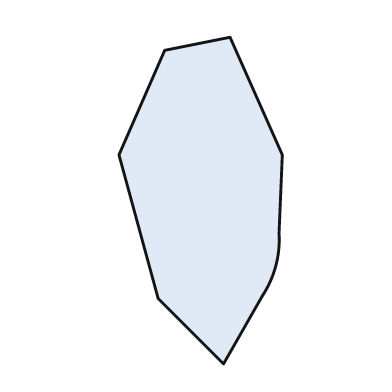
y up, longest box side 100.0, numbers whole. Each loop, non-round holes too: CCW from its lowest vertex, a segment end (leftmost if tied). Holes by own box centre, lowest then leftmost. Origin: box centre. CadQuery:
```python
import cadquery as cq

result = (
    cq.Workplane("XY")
    .moveTo(7.0, -50.0)
    .lineTo(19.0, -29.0)
    .threePointArc((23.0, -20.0), (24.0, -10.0))
    .lineTo(25.0, 14.0)
    .lineTo(9.0, 50.0)
    .lineTo(-11.0, 46.0)
    .lineTo(-25.0, 14.0)
    .lineTo(-13.0, -30.0)
    .close()
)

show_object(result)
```